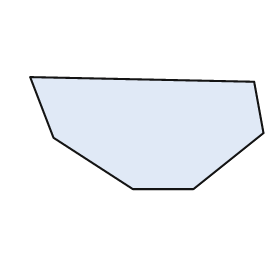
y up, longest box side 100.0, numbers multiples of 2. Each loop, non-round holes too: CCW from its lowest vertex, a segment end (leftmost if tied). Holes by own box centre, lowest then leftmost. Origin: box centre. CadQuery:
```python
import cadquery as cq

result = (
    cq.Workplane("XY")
    .moveTo(-6.0, -24.0)
    .lineTo(20.0, -24.0)
    .lineTo(50.0, 0.0)
    .lineTo(46.0, 22.0)
    .lineTo(-50.0, 24.0)
    .lineTo(-40.0, -2.0)
    .close()
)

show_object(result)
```